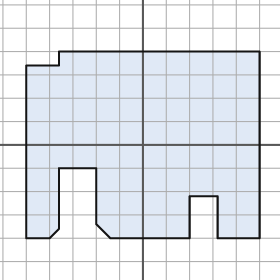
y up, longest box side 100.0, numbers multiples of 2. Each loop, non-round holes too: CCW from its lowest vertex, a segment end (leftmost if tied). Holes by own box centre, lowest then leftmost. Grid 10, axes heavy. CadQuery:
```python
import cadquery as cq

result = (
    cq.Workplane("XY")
    .moveTo(-50.0, -40.0)
    .lineTo(-40.0, -40.0)
    .lineTo(-36.0, -36.0)
    .lineTo(-36.0, -10.0)
    .lineTo(-20.0, -10.0)
    .lineTo(-20.0, -34.0)
    .lineTo(-14.0, -40.0)
    .lineTo(20.0, -40.0)
    .lineTo(20.0, -22.0)
    .lineTo(32.0, -22.0)
    .lineTo(32.0, -40.0)
    .lineTo(50.0, -40.0)
    .lineTo(50.0, 40.0)
    .lineTo(-36.0, 40.0)
    .lineTo(-36.0, 34.0)
    .lineTo(-50.0, 34.0)
    .close()
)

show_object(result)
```